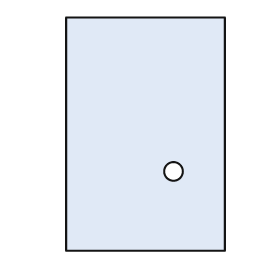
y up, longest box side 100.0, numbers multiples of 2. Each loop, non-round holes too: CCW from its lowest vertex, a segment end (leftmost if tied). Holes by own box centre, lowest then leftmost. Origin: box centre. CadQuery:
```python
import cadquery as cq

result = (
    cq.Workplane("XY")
    .moveTo(-34.0, -50.0)
    .lineTo(34.0, -50.0)
    .lineTo(34.0, 50.0)
    .lineTo(-34.0, 50.0)
    .close()
    .moveTo(12.0, -16.0)
    .circle(4.0)
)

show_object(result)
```